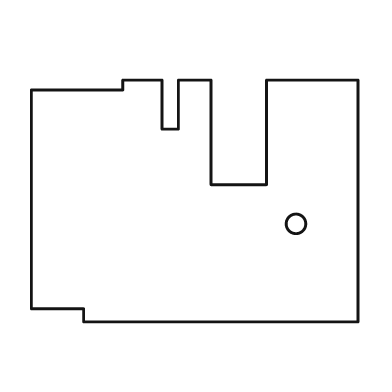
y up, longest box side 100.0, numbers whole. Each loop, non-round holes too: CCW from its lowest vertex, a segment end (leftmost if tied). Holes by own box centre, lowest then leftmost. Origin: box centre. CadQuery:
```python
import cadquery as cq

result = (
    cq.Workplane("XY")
    .moveTo(-34.0, -37.0)
    .lineTo(50.0, -37.0)
    .lineTo(50.0, 37.0)
    .lineTo(22.0, 37.0)
    .lineTo(22.0, 5.0)
    .lineTo(5.0, 5.0)
    .lineTo(5.0, 37.0)
    .lineTo(-5.0, 37.0)
    .lineTo(-5.0, 22.0)
    .lineTo(-10.0, 22.0)
    .lineTo(-10.0, 37.0)
    .lineTo(-22.0, 37.0)
    .lineTo(-22.0, 34.0)
    .lineTo(-50.0, 34.0)
    .lineTo(-50.0, -33.0)
    .lineTo(-34.0, -33.0)
    .close()
    .moveTo(31.0, -7.0)
    .circle(3.0)
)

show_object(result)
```